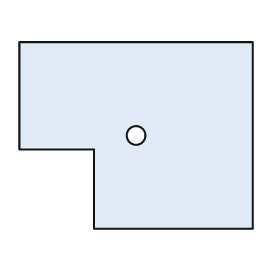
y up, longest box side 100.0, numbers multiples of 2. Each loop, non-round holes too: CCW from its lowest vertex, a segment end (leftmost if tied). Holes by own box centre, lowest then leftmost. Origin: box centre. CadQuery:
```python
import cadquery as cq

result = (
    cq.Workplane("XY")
    .moveTo(-18.0, -40.0)
    .lineTo(50.0, -40.0)
    .lineTo(50.0, 40.0)
    .lineTo(-50.0, 40.0)
    .lineTo(-50.0, -6.0)
    .lineTo(-18.0, -6.0)
    .close()
    .moveTo(0.0, 0.0)
    .circle(4.0)
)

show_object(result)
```